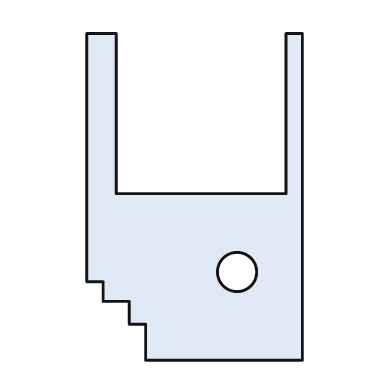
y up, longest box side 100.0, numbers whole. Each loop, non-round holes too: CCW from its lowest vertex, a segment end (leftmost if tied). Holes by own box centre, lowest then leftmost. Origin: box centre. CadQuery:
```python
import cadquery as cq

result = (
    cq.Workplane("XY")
    .moveTo(-15.0, -50.0)
    .lineTo(33.0, -50.0)
    .lineTo(33.0, 50.0)
    .lineTo(28.0, 50.0)
    .lineTo(28.0, 1.0)
    .lineTo(-24.0, 1.0)
    .lineTo(-24.0, 50.0)
    .lineTo(-33.0, 50.0)
    .lineTo(-33.0, -26.0)
    .lineTo(-28.0, -26.0)
    .lineTo(-28.0, -32.0)
    .lineTo(-20.0, -32.0)
    .lineTo(-20.0, -39.0)
    .lineTo(-15.0, -39.0)
    .close()
    .moveTo(13.0, -23.0)
    .circle(6.0)
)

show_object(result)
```